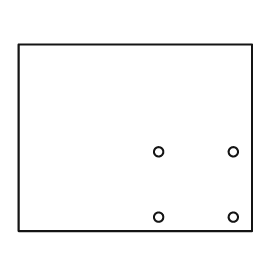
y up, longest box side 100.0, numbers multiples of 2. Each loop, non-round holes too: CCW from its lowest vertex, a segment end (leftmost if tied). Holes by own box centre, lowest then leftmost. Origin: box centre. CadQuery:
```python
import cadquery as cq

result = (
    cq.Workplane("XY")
    .moveTo(-50.0, -40.0)
    .lineTo(50.0, -40.0)
    .lineTo(50.0, 40.0)
    .lineTo(-50.0, 40.0)
    .close()
    .moveTo(10.0, -34.0)
    .circle(2.0)
    .moveTo(42.0, -34.0)
    .circle(2.0)
    .moveTo(10.0, -6.0)
    .circle(2.0)
    .moveTo(42.0, -6.0)
    .circle(2.0)
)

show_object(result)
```